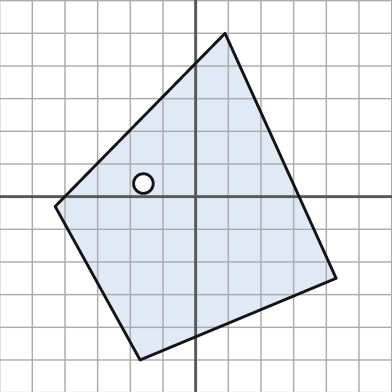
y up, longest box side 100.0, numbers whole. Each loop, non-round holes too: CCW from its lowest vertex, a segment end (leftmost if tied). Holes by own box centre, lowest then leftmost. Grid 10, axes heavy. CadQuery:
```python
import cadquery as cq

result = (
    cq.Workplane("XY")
    .moveTo(-17.0, -50.0)
    .lineTo(43.0, -25.0)
    .lineTo(9.0, 50.0)
    .lineTo(-43.0, -3.0)
    .close()
    .moveTo(-16.0, 4.0)
    .circle(3.0)
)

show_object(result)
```